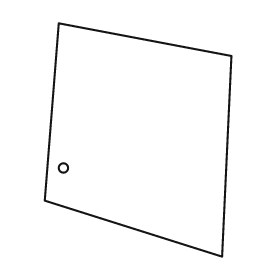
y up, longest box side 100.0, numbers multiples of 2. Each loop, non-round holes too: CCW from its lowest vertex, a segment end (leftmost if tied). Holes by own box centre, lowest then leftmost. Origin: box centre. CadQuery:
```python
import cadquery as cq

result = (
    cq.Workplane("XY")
    .moveTo(36.0, -50.0)
    .lineTo(40.0, 36.0)
    .lineTo(-34.0, 50.0)
    .lineTo(-40.0, -26.0)
    .close()
    .moveTo(-32.0, -12.0)
    .circle(2.0)
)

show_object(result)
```